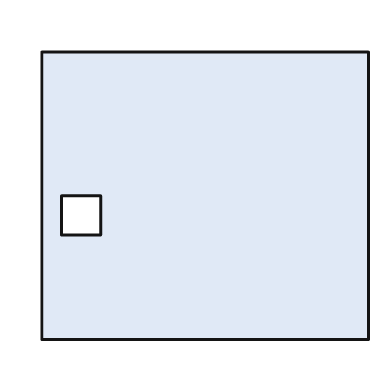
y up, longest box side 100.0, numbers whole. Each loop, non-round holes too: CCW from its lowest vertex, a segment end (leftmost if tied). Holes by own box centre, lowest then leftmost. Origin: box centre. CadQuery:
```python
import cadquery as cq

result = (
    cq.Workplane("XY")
    .moveTo(-50.0, -44.0)
    .lineTo(50.0, -44.0)
    .lineTo(50.0, 44.0)
    .lineTo(-50.0, 44.0)
    .close()
    .moveTo(-44.0, -12.0)
    .lineTo(-32.0, -12.0)
    .lineTo(-32.0, 0.0)
    .lineTo(-44.0, 0.0)
    .close()
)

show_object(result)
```